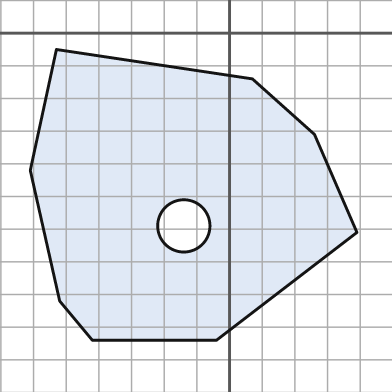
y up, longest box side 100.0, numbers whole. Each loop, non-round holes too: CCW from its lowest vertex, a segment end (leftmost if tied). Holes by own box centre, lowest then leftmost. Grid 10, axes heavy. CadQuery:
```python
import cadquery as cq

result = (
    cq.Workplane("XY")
    .moveTo(-42.0, -94.0)
    .lineTo(-4.0, -94.0)
    .lineTo(39.0, -61.0)
    .lineTo(26.0, -31.0)
    .lineTo(7.0, -14.0)
    .lineTo(-53.0, -5.0)
    .lineTo(-61.0, -42.0)
    .lineTo(-52.0, -82.0)
    .close()
    .moveTo(-14.0, -59.0)
    .circle(8.0)
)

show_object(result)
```